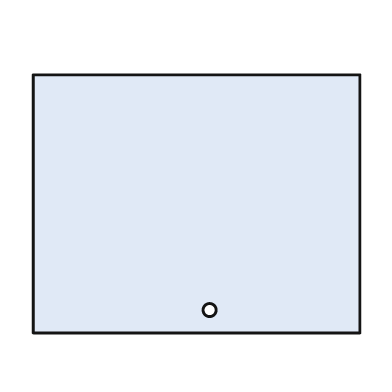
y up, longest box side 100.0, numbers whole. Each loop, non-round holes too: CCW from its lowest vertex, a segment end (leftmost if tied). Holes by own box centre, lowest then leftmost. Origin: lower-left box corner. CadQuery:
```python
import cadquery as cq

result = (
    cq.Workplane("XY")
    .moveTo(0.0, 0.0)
    .lineTo(100.0, 0.0)
    .lineTo(100.0, 79.0)
    .lineTo(0.0, 79.0)
    .close()
    .moveTo(54.0, 7.0)
    .circle(2.0)
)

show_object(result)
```